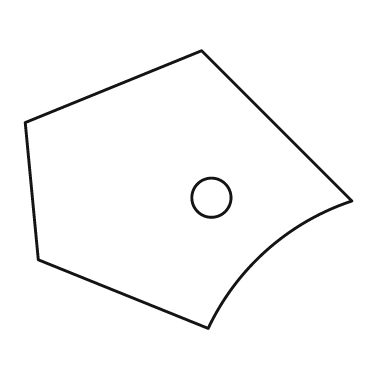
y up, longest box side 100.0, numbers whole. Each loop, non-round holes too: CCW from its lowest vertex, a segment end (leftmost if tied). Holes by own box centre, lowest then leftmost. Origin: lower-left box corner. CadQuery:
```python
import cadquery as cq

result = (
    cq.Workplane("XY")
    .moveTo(56.0, 0.0)
    .threePointArc((74.0, 24.0), (100.0, 39.0))
    .lineTo(54.0, 85.0)
    .lineTo(0.0, 63.0)
    .lineTo(4.0, 21.0)
    .close()
    .moveTo(57.0, 40.0)
    .circle(6.0)
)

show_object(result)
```